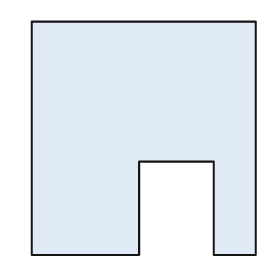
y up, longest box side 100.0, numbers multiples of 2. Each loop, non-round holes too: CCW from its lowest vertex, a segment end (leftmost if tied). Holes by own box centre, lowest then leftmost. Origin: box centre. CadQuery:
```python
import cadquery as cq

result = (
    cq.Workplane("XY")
    .moveTo(-48.0, -50.0)
    .lineTo(-2.0, -50.0)
    .lineTo(-2.0, -10.0)
    .lineTo(30.0, -10.0)
    .lineTo(30.0, -50.0)
    .lineTo(48.0, -50.0)
    .lineTo(48.0, 50.0)
    .lineTo(-48.0, 50.0)
    .close()
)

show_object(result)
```